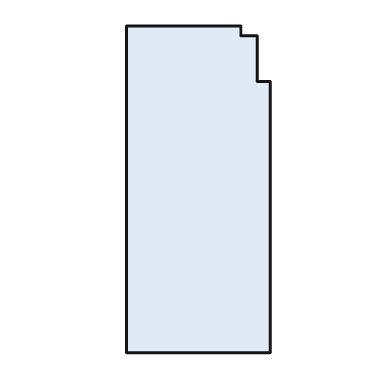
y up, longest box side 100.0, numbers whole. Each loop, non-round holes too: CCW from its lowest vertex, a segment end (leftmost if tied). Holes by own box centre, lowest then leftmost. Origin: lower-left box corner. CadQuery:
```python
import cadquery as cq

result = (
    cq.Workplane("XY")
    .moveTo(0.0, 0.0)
    .lineTo(44.0, 0.0)
    .lineTo(44.0, 83.0)
    .lineTo(40.0, 83.0)
    .lineTo(40.0, 97.0)
    .lineTo(35.0, 97.0)
    .lineTo(35.0, 100.0)
    .lineTo(0.0, 100.0)
    .close()
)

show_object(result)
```